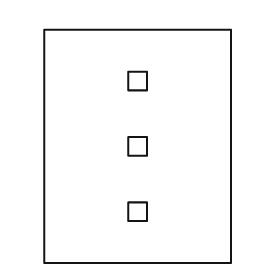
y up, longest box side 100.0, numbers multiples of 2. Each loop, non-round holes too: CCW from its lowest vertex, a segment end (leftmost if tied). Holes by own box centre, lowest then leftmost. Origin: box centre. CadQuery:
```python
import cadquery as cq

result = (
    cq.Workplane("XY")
    .moveTo(-40.0, -50.0)
    .lineTo(40.0, -50.0)
    .lineTo(40.0, 50.0)
    .lineTo(-40.0, 50.0)
    .close()
    .moveTo(-4.0, -32.0)
    .lineTo(4.0, -32.0)
    .lineTo(4.0, -24.0)
    .lineTo(-4.0, -24.0)
    .close()
    .moveTo(-4.0, -4.0)
    .lineTo(4.0, -4.0)
    .lineTo(4.0, 4.0)
    .lineTo(-4.0, 4.0)
    .close()
    .moveTo(-4.0, 24.0)
    .lineTo(4.0, 24.0)
    .lineTo(4.0, 32.0)
    .lineTo(-4.0, 32.0)
    .close()
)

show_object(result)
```